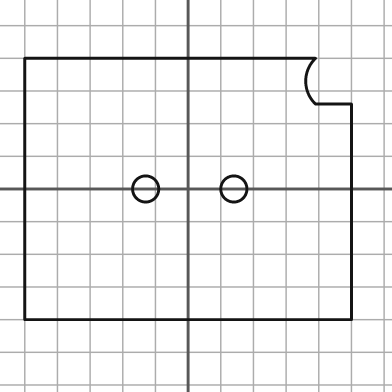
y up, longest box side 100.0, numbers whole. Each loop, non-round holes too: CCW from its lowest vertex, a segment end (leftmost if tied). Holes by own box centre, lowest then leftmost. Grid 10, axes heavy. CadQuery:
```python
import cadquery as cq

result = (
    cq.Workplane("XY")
    .moveTo(-50.0, -40.0)
    .lineTo(50.0, -40.0)
    .lineTo(50.0, 26.0)
    .lineTo(39.0, 26.0)
    .threePointArc((36.0, 33.0), (39.0, 40.0))
    .lineTo(-50.0, 40.0)
    .close()
    .moveTo(-13.0, 0.0)
    .circle(4.0)
    .moveTo(14.0, 0.0)
    .circle(4.0)
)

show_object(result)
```